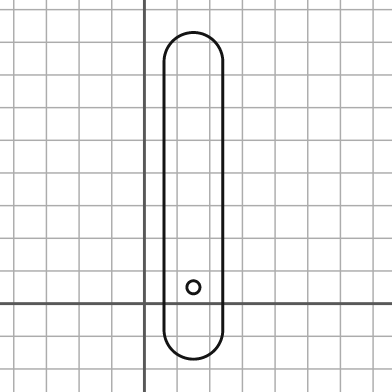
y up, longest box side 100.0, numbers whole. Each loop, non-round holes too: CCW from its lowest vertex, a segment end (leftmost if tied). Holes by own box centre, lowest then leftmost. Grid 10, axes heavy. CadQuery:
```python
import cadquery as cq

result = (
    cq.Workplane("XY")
    .moveTo(6.0, -8.0)
    .threePointArc((15.0, -17.0), (24.0, -8.0))
    .lineTo(24.0, 74.0)
    .threePointArc((15.0, 83.0), (6.0, 74.0))
    .close()
    .moveTo(15.0, 5.0)
    .circle(2.0)
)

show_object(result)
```